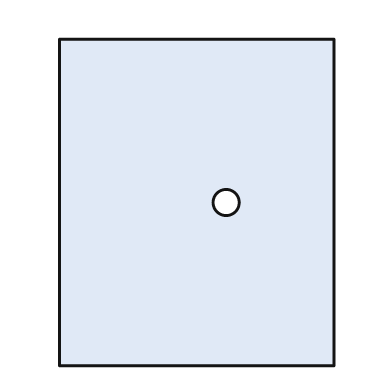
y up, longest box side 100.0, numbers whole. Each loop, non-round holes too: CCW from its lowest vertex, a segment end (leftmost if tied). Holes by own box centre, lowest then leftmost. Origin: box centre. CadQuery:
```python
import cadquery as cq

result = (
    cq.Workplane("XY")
    .moveTo(-42.0, -50.0)
    .lineTo(42.0, -50.0)
    .lineTo(42.0, 50.0)
    .lineTo(-42.0, 50.0)
    .close()
    .moveTo(9.0, 0.0)
    .circle(4.0)
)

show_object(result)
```